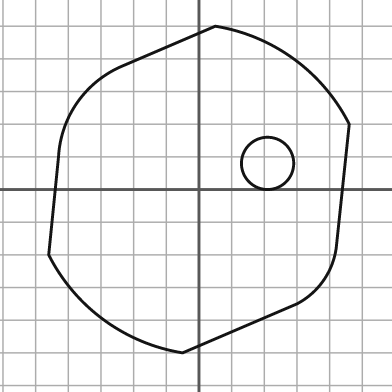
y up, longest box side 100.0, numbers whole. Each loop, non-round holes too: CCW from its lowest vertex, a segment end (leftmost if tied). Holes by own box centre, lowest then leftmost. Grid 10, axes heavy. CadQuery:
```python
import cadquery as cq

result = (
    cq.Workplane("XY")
    .moveTo(-5.0, -50.0)
    .lineTo(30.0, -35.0)
    .threePointArc((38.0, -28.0), (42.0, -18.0))
    .lineTo(46.0, 20.0)
    .threePointArc((29.0, 40.0), (5.0, 50.0))
    .lineTo(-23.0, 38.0)
    .threePointArc((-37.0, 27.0), (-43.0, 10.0))
    .lineTo(-46.0, -20.0)
    .threePointArc((-29.0, -40.0), (-5.0, -50.0))
    .close()
    .moveTo(21.0, 8.0)
    .circle(8.0)
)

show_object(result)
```